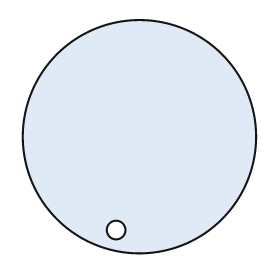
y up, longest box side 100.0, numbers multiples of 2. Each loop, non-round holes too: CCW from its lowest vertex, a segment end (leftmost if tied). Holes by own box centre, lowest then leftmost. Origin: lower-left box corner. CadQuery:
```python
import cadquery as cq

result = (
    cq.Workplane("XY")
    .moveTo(50.0, 50.0)
    .circle(50.0)
    .moveTo(40.0, 10.0)
    .circle(4.0)
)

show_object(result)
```